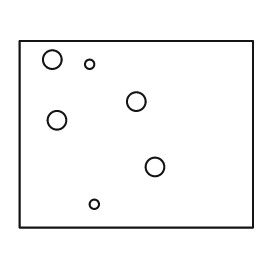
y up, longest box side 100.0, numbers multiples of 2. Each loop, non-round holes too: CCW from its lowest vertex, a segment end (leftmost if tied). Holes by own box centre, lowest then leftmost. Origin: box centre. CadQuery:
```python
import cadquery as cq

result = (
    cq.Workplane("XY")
    .moveTo(-50.0, -40.0)
    .lineTo(50.0, -40.0)
    .lineTo(50.0, 40.0)
    .lineTo(-50.0, 40.0)
    .close()
    .moveTo(-18.0, -30.0)
    .circle(2.0)
    .moveTo(8.0, -14.0)
    .circle(4.0)
    .moveTo(-34.0, 6.0)
    .circle(4.0)
    .moveTo(0.0, 14.0)
    .circle(4.0)
    .moveTo(-20.0, 30.0)
    .circle(2.0)
    .moveTo(-36.0, 32.0)
    .circle(4.0)
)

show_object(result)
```